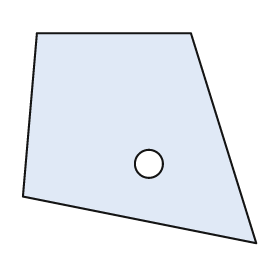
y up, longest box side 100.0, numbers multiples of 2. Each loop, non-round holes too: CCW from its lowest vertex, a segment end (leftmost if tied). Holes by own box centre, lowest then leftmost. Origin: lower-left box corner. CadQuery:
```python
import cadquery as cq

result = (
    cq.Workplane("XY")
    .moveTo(100.0, 0.0)
    .lineTo(72.0, 90.0)
    .lineTo(6.0, 90.0)
    .lineTo(0.0, 20.0)
    .close()
    .moveTo(54.0, 34.0)
    .circle(6.0)
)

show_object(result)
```